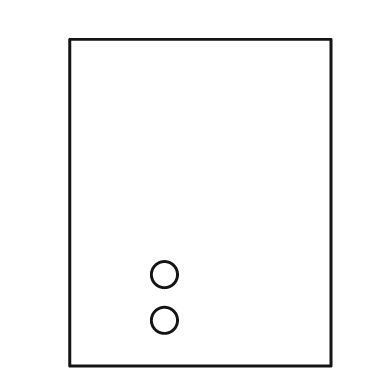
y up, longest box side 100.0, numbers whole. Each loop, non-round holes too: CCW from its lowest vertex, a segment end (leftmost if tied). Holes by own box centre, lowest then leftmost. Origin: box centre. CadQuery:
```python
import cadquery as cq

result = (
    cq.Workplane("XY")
    .moveTo(-40.0, -50.0)
    .lineTo(40.0, -50.0)
    .lineTo(40.0, 50.0)
    .lineTo(-40.0, 50.0)
    .close()
    .moveTo(-11.0, -36.0)
    .circle(4.0)
    .moveTo(-11.0, -22.0)
    .circle(4.0)
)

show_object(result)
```